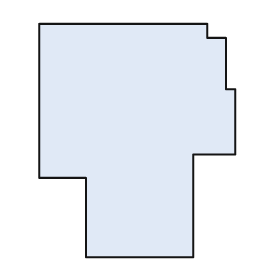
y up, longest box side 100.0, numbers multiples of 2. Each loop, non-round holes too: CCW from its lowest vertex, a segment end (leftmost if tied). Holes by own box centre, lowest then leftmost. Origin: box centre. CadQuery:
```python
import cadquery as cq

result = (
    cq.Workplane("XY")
    .moveTo(-22.0, -50.0)
    .lineTo(24.0, -50.0)
    .lineTo(24.0, -6.0)
    .lineTo(42.0, -6.0)
    .lineTo(42.0, 22.0)
    .lineTo(38.0, 22.0)
    .lineTo(38.0, 44.0)
    .lineTo(30.0, 44.0)
    .lineTo(30.0, 50.0)
    .lineTo(-42.0, 50.0)
    .lineTo(-42.0, -16.0)
    .lineTo(-22.0, -16.0)
    .close()
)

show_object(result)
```